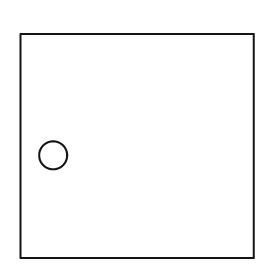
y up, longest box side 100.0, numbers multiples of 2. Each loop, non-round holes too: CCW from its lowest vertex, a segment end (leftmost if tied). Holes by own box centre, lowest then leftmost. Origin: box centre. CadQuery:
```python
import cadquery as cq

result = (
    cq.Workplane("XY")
    .moveTo(-50.0, -48.0)
    .lineTo(50.0, -48.0)
    .lineTo(50.0, 48.0)
    .lineTo(-50.0, 48.0)
    .close()
    .moveTo(-36.0, -4.0)
    .circle(6.0)
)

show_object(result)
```